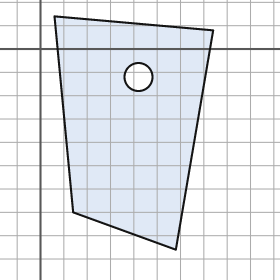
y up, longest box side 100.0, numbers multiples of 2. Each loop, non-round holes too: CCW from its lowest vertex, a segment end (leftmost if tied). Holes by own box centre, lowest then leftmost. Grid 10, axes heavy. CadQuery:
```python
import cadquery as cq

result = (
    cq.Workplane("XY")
    .moveTo(58.0, -86.0)
    .lineTo(74.0, 8.0)
    .lineTo(6.0, 14.0)
    .lineTo(14.0, -70.0)
    .close()
    .moveTo(42.0, -12.0)
    .circle(6.0)
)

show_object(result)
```